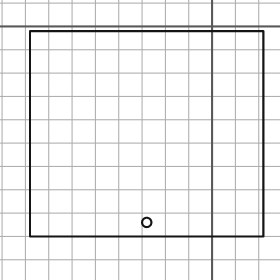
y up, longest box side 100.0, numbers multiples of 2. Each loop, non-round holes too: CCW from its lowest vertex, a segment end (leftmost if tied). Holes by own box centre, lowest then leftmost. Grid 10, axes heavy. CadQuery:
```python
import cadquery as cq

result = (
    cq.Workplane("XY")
    .moveTo(-78.0, -90.0)
    .lineTo(22.0, -90.0)
    .lineTo(22.0, -2.0)
    .lineTo(-78.0, -2.0)
    .close()
    .moveTo(-28.0, -84.0)
    .circle(2.0)
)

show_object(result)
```